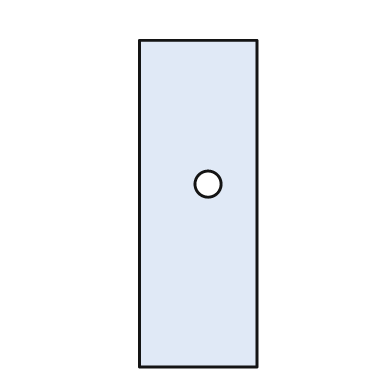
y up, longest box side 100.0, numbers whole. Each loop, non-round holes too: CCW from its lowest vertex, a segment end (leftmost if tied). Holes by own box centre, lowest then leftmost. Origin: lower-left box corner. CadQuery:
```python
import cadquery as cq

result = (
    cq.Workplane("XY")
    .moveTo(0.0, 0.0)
    .lineTo(36.0, 0.0)
    .lineTo(36.0, 100.0)
    .lineTo(0.0, 100.0)
    .close()
    .moveTo(21.0, 56.0)
    .circle(4.0)
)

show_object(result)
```